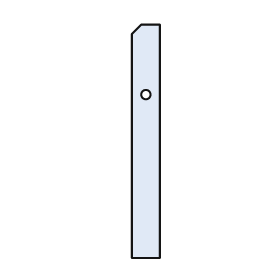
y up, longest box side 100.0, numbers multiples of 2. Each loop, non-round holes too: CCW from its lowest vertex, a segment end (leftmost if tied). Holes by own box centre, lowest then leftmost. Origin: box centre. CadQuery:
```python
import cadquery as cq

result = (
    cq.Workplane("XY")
    .moveTo(-6.0, -50.0)
    .lineTo(6.0, -50.0)
    .lineTo(6.0, 50.0)
    .lineTo(-2.0, 50.0)
    .lineTo(-6.0, 46.0)
    .close()
    .moveTo(0.0, 20.0)
    .circle(2.0)
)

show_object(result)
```